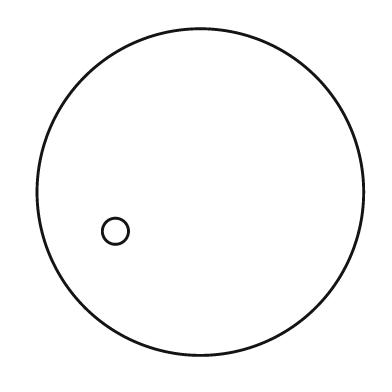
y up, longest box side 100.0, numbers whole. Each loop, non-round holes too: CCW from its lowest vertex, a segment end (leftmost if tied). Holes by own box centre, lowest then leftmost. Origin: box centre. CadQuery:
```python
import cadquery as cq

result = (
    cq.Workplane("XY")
    .moveTo(0.0, 0.0)
    .circle(50.0)
    .moveTo(-26.0, -12.0)
    .circle(4.0)
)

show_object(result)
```